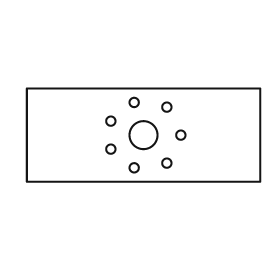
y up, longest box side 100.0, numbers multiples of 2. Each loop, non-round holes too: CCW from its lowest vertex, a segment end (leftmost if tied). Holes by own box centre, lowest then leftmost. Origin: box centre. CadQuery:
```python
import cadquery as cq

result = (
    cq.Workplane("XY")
    .moveTo(-50.0, -20.0)
    .lineTo(50.0, -20.0)
    .lineTo(50.0, 20.0)
    .lineTo(-50.0, 20.0)
    .close()
    .moveTo(-4.0, -14.0)
    .circle(2.0)
    .moveTo(10.0, -12.0)
    .circle(2.0)
    .moveTo(-14.0, -6.0)
    .circle(2.0)
    .moveTo(0.0, 0.0)
    .circle(6.0)
    .moveTo(16.0, 0.0)
    .circle(2.0)
    .moveTo(-14.0, 6.0)
    .circle(2.0)
    .moveTo(10.0, 12.0)
    .circle(2.0)
    .moveTo(-4.0, 14.0)
    .circle(2.0)
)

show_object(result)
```